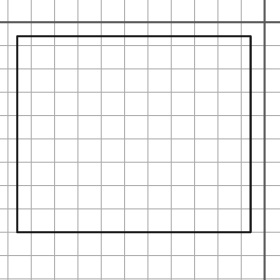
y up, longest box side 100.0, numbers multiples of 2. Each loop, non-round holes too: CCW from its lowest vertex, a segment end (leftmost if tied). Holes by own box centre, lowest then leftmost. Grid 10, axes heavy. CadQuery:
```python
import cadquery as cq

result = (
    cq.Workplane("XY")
    .moveTo(-106.0, -90.0)
    .lineTo(-6.0, -90.0)
    .lineTo(-6.0, -6.0)
    .lineTo(-106.0, -6.0)
    .close()
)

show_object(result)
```